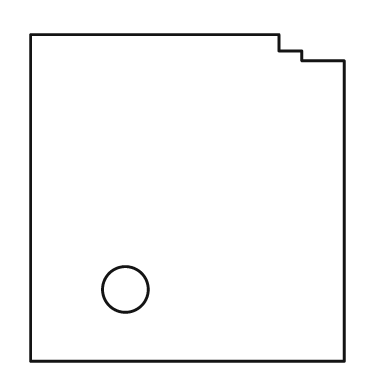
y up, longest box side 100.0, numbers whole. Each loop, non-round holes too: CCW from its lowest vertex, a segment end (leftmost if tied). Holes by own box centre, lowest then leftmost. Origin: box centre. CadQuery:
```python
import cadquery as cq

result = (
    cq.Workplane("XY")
    .moveTo(-48.0, -50.0)
    .lineTo(48.0, -50.0)
    .lineTo(48.0, 42.0)
    .lineTo(35.0, 42.0)
    .lineTo(35.0, 45.0)
    .lineTo(28.0, 45.0)
    .lineTo(28.0, 50.0)
    .lineTo(-48.0, 50.0)
    .close()
    .moveTo(-19.0, -28.0)
    .circle(7.0)
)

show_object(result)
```